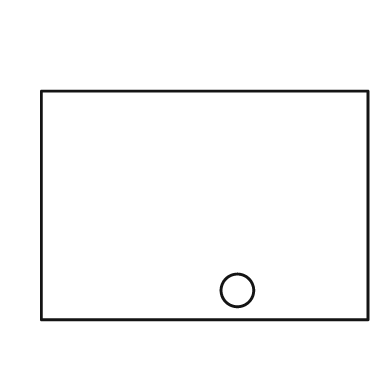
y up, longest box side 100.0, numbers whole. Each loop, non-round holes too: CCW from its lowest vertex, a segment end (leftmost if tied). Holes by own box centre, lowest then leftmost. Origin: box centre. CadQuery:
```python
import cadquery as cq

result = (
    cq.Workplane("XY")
    .moveTo(-50.0, -35.0)
    .lineTo(50.0, -35.0)
    .lineTo(50.0, 35.0)
    .lineTo(-50.0, 35.0)
    .close()
    .moveTo(10.0, -26.0)
    .circle(5.0)
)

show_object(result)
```